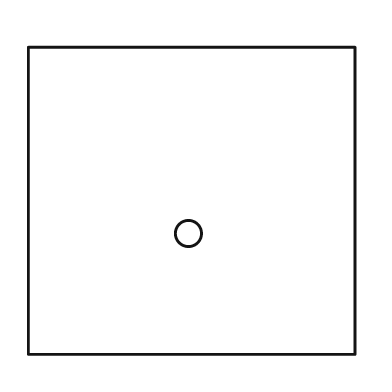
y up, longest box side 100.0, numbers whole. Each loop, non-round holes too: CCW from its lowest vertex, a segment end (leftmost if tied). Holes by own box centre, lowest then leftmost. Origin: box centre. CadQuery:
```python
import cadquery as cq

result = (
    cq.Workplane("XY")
    .moveTo(-50.0, -47.0)
    .lineTo(50.0, -47.0)
    .lineTo(50.0, 47.0)
    .lineTo(-50.0, 47.0)
    .close()
    .moveTo(-1.0, -10.0)
    .circle(4.0)
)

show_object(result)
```